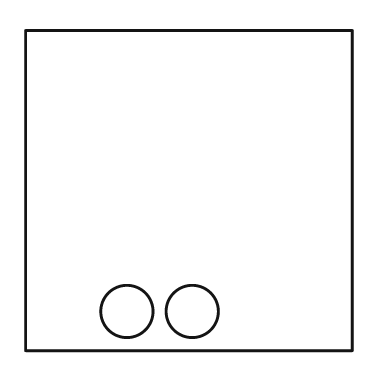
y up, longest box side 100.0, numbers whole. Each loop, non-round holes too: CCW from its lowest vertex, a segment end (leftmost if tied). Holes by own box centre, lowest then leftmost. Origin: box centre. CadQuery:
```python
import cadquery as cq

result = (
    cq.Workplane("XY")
    .moveTo(-50.0, -49.0)
    .lineTo(50.0, -49.0)
    .lineTo(50.0, 49.0)
    .lineTo(-50.0, 49.0)
    .close()
    .moveTo(-19.0, -37.0)
    .circle(8.0)
    .moveTo(1.0, -37.0)
    .circle(8.0)
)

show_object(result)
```